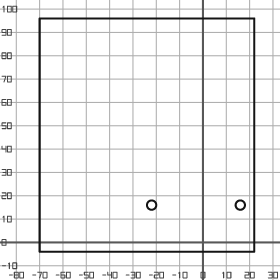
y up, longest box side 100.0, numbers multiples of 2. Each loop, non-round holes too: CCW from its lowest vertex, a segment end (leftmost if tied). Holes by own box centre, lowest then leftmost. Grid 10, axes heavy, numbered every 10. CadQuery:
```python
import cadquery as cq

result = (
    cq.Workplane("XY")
    .moveTo(-70.0, -4.0)
    .lineTo(22.0, -4.0)
    .lineTo(22.0, 96.0)
    .lineTo(-70.0, 96.0)
    .close()
    .moveTo(-22.0, 16.0)
    .circle(2.0)
    .moveTo(16.0, 16.0)
    .circle(2.0)
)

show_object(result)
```